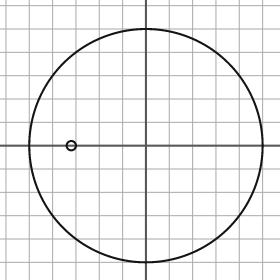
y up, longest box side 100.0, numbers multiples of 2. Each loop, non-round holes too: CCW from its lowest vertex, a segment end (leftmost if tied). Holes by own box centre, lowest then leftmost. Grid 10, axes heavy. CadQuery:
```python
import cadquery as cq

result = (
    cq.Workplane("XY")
    .moveTo(0.0, 0.0)
    .circle(50.0)
    .moveTo(-32.0, 0.0)
    .circle(2.0)
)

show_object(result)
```